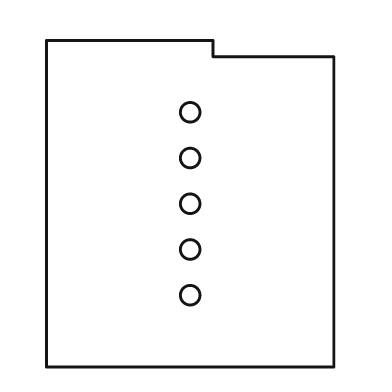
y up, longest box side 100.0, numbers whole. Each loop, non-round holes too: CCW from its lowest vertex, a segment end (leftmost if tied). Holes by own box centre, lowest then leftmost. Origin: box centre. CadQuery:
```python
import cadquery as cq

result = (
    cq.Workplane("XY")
    .moveTo(-44.0, -50.0)
    .lineTo(44.0, -50.0)
    .lineTo(44.0, 45.0)
    .lineTo(7.0, 45.0)
    .lineTo(7.0, 50.0)
    .lineTo(-44.0, 50.0)
    .close()
    .moveTo(0.0, -28.0)
    .circle(3.0)
    .moveTo(0.0, -14.0)
    .circle(3.0)
    .moveTo(0.0, 0.0)
    .circle(3.0)
    .moveTo(0.0, 14.0)
    .circle(3.0)
    .moveTo(0.0, 28.0)
    .circle(3.0)
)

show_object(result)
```